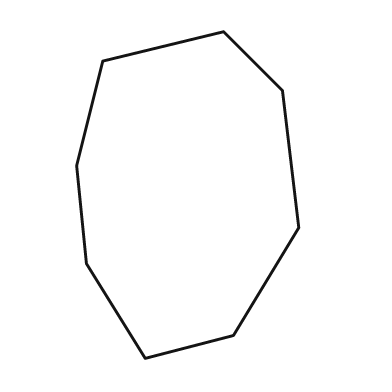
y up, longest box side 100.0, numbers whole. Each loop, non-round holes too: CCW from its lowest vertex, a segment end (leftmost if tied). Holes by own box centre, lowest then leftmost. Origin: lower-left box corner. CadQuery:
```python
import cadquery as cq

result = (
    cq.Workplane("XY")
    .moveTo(21.0, 0.0)
    .lineTo(48.0, 7.0)
    .lineTo(68.0, 40.0)
    .lineTo(63.0, 82.0)
    .lineTo(45.0, 100.0)
    .lineTo(8.0, 91.0)
    .lineTo(0.0, 59.0)
    .lineTo(3.0, 29.0)
    .close()
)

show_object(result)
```